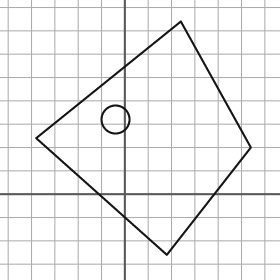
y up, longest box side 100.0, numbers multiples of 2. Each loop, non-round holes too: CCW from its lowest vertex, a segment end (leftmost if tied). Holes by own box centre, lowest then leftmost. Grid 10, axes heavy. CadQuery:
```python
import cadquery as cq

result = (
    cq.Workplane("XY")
    .moveTo(18.0, -26.0)
    .lineTo(54.0, 20.0)
    .lineTo(24.0, 74.0)
    .lineTo(-38.0, 24.0)
    .close()
    .moveTo(-4.0, 32.0)
    .circle(6.0)
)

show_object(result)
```